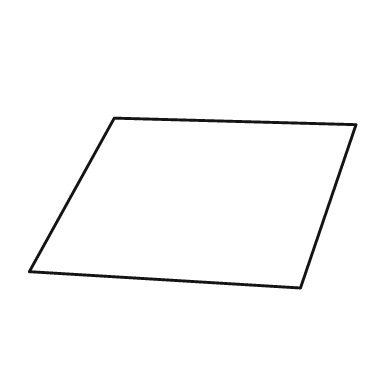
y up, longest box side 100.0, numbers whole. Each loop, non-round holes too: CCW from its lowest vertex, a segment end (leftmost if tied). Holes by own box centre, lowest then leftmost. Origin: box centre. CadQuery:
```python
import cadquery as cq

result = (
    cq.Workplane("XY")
    .moveTo(33.0, -26.0)
    .lineTo(50.0, 24.0)
    .lineTo(-24.0, 26.0)
    .lineTo(-50.0, -21.0)
    .close()
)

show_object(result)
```